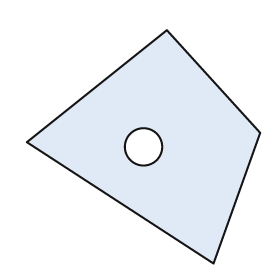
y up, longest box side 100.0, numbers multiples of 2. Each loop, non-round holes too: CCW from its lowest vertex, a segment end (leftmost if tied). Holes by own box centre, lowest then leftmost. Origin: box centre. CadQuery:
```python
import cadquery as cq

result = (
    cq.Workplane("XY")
    .moveTo(30.0, -50.0)
    .lineTo(50.0, 6.0)
    .lineTo(10.0, 50.0)
    .lineTo(-50.0, 2.0)
    .close()
    .moveTo(0.0, 0.0)
    .circle(8.0)
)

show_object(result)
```